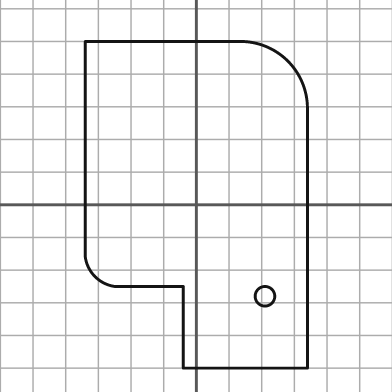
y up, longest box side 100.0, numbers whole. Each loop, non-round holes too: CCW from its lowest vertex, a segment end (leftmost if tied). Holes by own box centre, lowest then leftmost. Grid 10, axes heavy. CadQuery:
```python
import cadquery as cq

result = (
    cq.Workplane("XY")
    .moveTo(-4.0, -50.0)
    .lineTo(34.0, -50.0)
    .lineTo(34.0, 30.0)
    .threePointArc((28.0, 44.0), (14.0, 50.0))
    .lineTo(-34.0, 50.0)
    .lineTo(-34.0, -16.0)
    .threePointArc((-31.0, -22.0), (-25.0, -25.0))
    .lineTo(-4.0, -25.0)
    .close()
    .moveTo(21.0, -28.0)
    .circle(3.0)
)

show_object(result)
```